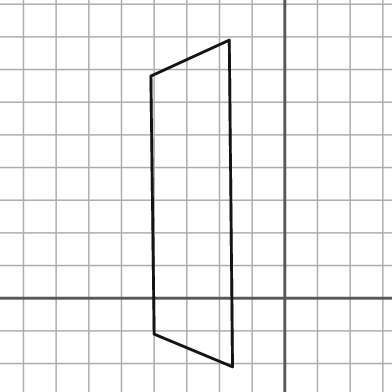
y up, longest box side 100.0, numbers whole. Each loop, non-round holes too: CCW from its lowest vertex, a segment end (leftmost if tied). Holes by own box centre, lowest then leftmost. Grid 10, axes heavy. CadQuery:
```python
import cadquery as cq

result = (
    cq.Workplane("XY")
    .moveTo(-16.0, -21.0)
    .lineTo(-17.0, 79.0)
    .lineTo(-41.0, 68.0)
    .lineTo(-40.0, -11.0)
    .close()
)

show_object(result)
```